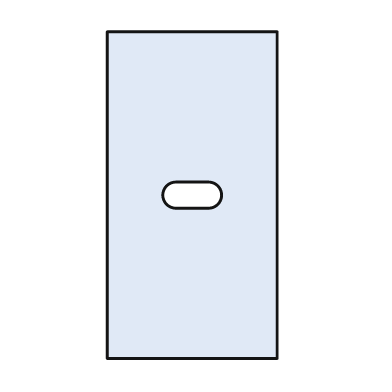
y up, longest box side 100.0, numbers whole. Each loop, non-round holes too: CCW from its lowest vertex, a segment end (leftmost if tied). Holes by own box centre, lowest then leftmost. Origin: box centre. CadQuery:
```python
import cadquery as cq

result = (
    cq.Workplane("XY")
    .moveTo(-26.0, -50.0)
    .lineTo(26.0, -50.0)
    .lineTo(26.0, 50.0)
    .lineTo(-26.0, 50.0)
    .close()
    .moveTo(-5.0, -4.0)
    .lineTo(5.0, -4.0)
    .threePointArc((9.0, 0.0), (5.0, 4.0))
    .lineTo(-5.0, 4.0)
    .threePointArc((-9.0, 0.0), (-5.0, -4.0))
    .close()
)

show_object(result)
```